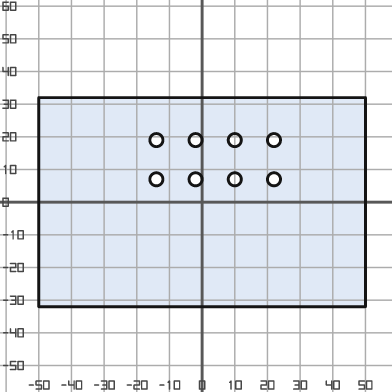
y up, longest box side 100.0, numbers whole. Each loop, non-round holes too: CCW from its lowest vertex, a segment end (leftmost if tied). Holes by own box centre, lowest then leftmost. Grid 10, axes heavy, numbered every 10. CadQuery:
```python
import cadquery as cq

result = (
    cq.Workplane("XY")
    .moveTo(-50.0, -32.0)
    .lineTo(50.0, -32.0)
    .lineTo(50.0, 32.0)
    .lineTo(-50.0, 32.0)
    .close()
    .moveTo(-14.0, 7.0)
    .circle(2.0)
    .moveTo(-2.0, 7.0)
    .circle(2.0)
    .moveTo(10.0, 7.0)
    .circle(2.0)
    .moveTo(22.0, 7.0)
    .circle(2.0)
    .moveTo(-14.0, 19.0)
    .circle(2.0)
    .moveTo(-2.0, 19.0)
    .circle(2.0)
    .moveTo(10.0, 19.0)
    .circle(2.0)
    .moveTo(22.0, 19.0)
    .circle(2.0)
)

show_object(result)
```